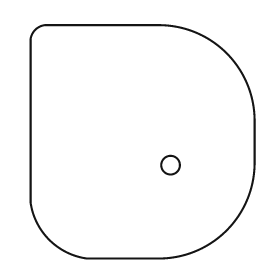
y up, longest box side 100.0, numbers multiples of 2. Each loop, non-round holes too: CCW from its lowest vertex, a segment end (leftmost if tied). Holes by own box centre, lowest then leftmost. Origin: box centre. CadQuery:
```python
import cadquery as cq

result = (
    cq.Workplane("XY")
    .moveTo(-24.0, -50.0)
    .lineTo(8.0, -50.0)
    .threePointArc((36.0, -38.0), (48.0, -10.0))
    .lineTo(48.0, 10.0)
    .threePointArc((36.0, 38.0), (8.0, 50.0))
    .lineTo(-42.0, 50.0)
    .threePointArc((-46.0, 48.0), (-48.0, 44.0))
    .lineTo(-48.0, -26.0)
    .threePointArc((-40.0, -42.0), (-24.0, -50.0))
    .close()
    .moveTo(12.0, -10.0)
    .circle(4.0)
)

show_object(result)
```